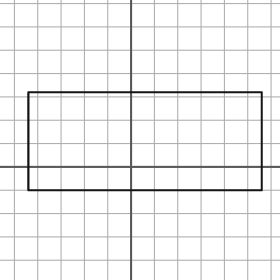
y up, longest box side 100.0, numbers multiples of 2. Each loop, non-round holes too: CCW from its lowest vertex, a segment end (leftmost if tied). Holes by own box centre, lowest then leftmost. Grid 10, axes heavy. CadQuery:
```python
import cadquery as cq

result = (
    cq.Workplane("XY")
    .moveTo(-44.0, -10.0)
    .lineTo(56.0, -10.0)
    .lineTo(56.0, 32.0)
    .lineTo(-44.0, 32.0)
    .close()
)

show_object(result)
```